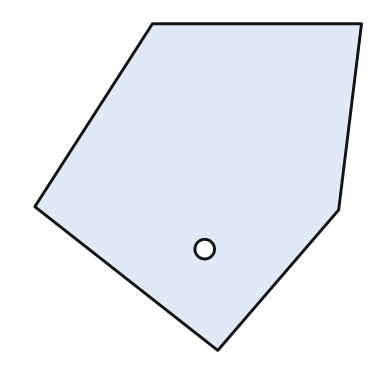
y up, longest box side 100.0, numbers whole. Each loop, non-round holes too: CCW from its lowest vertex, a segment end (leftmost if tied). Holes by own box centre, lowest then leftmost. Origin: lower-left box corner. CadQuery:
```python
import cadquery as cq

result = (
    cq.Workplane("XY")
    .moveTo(56.0, 0.0)
    .lineTo(93.0, 43.0)
    .lineTo(100.0, 100.0)
    .lineTo(36.0, 100.0)
    .lineTo(0.0, 44.0)
    .close()
    .moveTo(52.0, 31.0)
    .circle(3.0)
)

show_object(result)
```